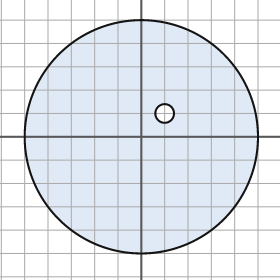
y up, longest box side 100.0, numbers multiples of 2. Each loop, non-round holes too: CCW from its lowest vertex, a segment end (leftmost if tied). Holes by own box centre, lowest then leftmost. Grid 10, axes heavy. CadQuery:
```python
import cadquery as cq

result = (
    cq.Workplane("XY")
    .moveTo(0.0, 0.0)
    .circle(50.0)
    .moveTo(10.0, 10.0)
    .circle(4.0)
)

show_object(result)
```